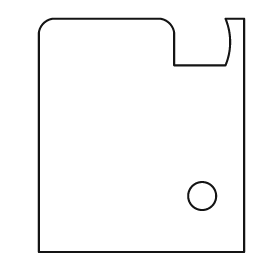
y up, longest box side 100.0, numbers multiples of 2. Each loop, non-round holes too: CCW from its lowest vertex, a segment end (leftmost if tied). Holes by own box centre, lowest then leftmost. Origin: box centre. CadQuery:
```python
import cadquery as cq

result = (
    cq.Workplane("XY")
    .moveTo(-44.0, -50.0)
    .lineTo(44.0, -50.0)
    .lineTo(44.0, 50.0)
    .lineTo(36.0, 50.0)
    .threePointArc((38.0, 40.0), (36.0, 30.0))
    .lineTo(14.0, 30.0)
    .lineTo(14.0, 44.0)
    .threePointArc((12.0, 48.0), (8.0, 50.0))
    .lineTo(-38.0, 50.0)
    .threePointArc((-42.0, 48.0), (-44.0, 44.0))
    .close()
    .moveTo(26.0, -26.0)
    .circle(6.0)
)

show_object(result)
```